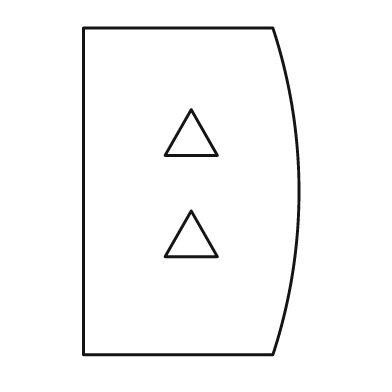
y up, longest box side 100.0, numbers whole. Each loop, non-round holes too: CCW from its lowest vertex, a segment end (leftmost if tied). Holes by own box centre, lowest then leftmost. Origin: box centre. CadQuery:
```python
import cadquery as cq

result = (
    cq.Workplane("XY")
    .moveTo(-33.0, -50.0)
    .lineTo(25.0, -50.0)
    .threePointArc((33.0, 0.0), (25.0, 50.0))
    .lineTo(-33.0, 50.0)
    .close()
    .moveTo(-8.0, -20.0)
    .lineTo(8.0, -20.0)
    .lineTo(0.0, -6.0)
    .close()
    .moveTo(-8.0, 11.0)
    .lineTo(8.0, 11.0)
    .lineTo(0.0, 25.0)
    .close()
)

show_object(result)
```